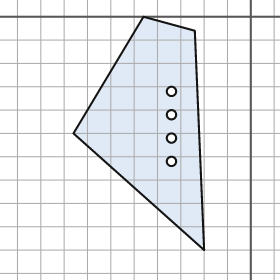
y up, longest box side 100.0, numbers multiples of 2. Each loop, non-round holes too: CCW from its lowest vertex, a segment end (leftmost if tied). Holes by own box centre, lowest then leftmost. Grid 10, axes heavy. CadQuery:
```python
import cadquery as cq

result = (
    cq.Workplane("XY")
    .moveTo(-20.0, -100.0)
    .lineTo(-24.0, -6.0)
    .lineTo(-46.0, 0.0)
    .lineTo(-76.0, -50.0)
    .close()
    .moveTo(-34.0, -62.0)
    .circle(2.0)
    .moveTo(-34.0, -52.0)
    .circle(2.0)
    .moveTo(-34.0, -42.0)
    .circle(2.0)
    .moveTo(-34.0, -32.0)
    .circle(2.0)
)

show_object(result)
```